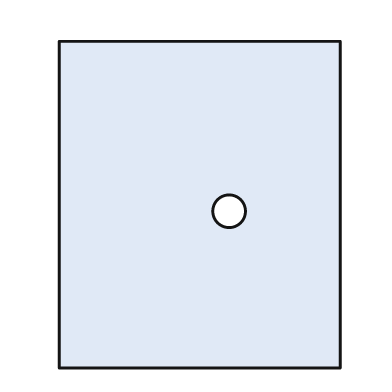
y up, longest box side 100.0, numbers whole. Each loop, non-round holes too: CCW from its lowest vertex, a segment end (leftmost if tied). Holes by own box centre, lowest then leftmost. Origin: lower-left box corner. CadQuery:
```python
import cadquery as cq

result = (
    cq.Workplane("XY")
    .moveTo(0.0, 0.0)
    .lineTo(86.0, 0.0)
    .lineTo(86.0, 100.0)
    .lineTo(0.0, 100.0)
    .close()
    .moveTo(52.0, 48.0)
    .circle(5.0)
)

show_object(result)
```